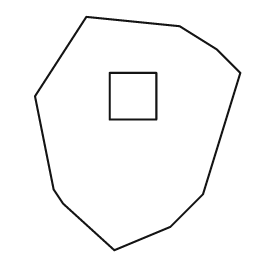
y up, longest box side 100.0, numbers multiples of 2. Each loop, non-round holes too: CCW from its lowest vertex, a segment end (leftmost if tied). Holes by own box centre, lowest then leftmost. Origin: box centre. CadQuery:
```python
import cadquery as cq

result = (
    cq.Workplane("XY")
    .moveTo(-10.0, -50.0)
    .lineTo(14.0, -40.0)
    .lineTo(28.0, -26.0)
    .lineTo(44.0, 26.0)
    .lineTo(34.0, 36.0)
    .lineTo(18.0, 46.0)
    .lineTo(-22.0, 50.0)
    .lineTo(-44.0, 16.0)
    .lineTo(-36.0, -24.0)
    .lineTo(-32.0, -30.0)
    .close()
    .moveTo(-12.0, 6.0)
    .lineTo(8.0, 6.0)
    .lineTo(8.0, 26.0)
    .lineTo(-12.0, 26.0)
    .close()
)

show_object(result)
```